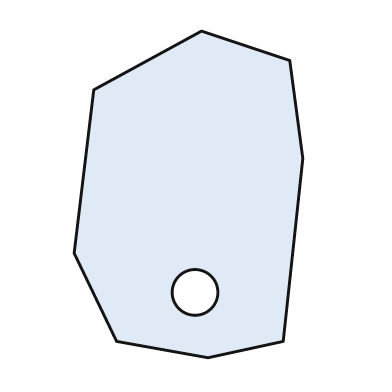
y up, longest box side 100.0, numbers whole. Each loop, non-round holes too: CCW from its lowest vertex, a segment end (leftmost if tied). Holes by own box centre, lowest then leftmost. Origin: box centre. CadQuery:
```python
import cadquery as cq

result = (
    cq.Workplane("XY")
    .moveTo(6.0, -50.0)
    .lineTo(29.0, -45.0)
    .lineTo(35.0, 11.0)
    .lineTo(31.0, 41.0)
    .lineTo(4.0, 50.0)
    .lineTo(-29.0, 32.0)
    .lineTo(-35.0, -18.0)
    .lineTo(-22.0, -45.0)
    .close()
    .moveTo(2.0, -30.0)
    .circle(7.0)
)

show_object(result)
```